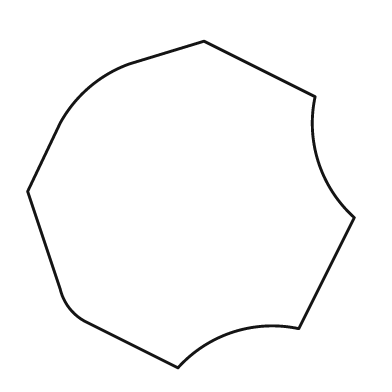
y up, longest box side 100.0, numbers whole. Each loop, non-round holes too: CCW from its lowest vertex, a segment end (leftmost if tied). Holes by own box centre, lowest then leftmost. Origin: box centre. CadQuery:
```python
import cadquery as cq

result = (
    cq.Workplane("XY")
    .moveTo(-4.0, -50.0)
    .threePointArc((13.0, -39.0), (33.0, -38.0))
    .lineTo(50.0, -4.0)
    .threePointArc((39.0, 13.0), (38.0, 33.0))
    .lineTo(4.0, 50.0)
    .lineTo(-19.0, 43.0)
    .threePointArc((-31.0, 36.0), (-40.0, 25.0))
    .lineTo(-50.0, 4.0)
    .lineTo(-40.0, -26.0)
    .threePointArc((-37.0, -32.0), (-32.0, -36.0))
    .close()
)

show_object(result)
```